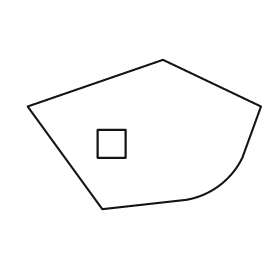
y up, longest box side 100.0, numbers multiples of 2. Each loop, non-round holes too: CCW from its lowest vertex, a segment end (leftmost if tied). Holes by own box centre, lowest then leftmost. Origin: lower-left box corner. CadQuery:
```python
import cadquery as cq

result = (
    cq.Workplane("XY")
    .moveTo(32.0, 0.0)
    .lineTo(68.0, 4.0)
    .threePointArc((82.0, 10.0), (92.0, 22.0))
    .lineTo(100.0, 44.0)
    .lineTo(58.0, 64.0)
    .lineTo(0.0, 44.0)
    .close()
    .moveTo(30.0, 22.0)
    .lineTo(42.0, 22.0)
    .lineTo(42.0, 34.0)
    .lineTo(30.0, 34.0)
    .close()
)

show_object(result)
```